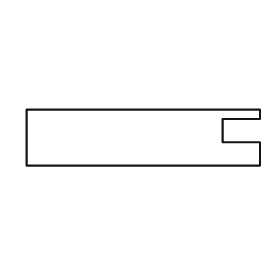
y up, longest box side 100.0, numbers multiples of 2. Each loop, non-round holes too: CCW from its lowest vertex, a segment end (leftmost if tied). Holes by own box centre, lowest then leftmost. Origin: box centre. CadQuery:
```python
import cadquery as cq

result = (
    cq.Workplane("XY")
    .moveTo(-50.0, -12.0)
    .lineTo(50.0, -12.0)
    .lineTo(50.0, -2.0)
    .lineTo(34.0, -2.0)
    .lineTo(34.0, 8.0)
    .lineTo(50.0, 8.0)
    .lineTo(50.0, 12.0)
    .lineTo(-50.0, 12.0)
    .close()
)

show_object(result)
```